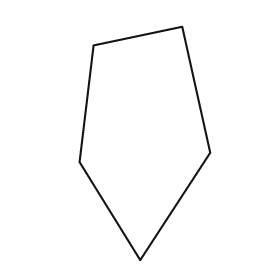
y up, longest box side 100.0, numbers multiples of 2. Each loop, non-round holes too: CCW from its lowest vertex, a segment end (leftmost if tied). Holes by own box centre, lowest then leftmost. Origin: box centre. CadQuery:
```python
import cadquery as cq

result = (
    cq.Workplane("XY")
    .moveTo(-2.0, -50.0)
    .lineTo(28.0, -4.0)
    .lineTo(16.0, 50.0)
    .lineTo(-22.0, 42.0)
    .lineTo(-28.0, -8.0)
    .close()
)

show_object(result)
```